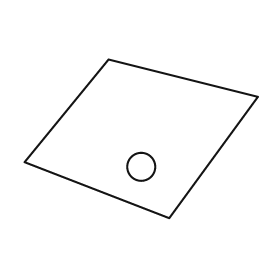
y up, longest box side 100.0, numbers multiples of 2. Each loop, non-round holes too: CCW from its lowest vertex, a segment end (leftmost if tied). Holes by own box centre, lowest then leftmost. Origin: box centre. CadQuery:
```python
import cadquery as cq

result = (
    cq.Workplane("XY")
    .moveTo(12.0, -34.0)
    .lineTo(50.0, 18.0)
    .lineTo(-14.0, 34.0)
    .lineTo(-50.0, -10.0)
    .close()
    .moveTo(0.0, -12.0)
    .circle(6.0)
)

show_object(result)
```